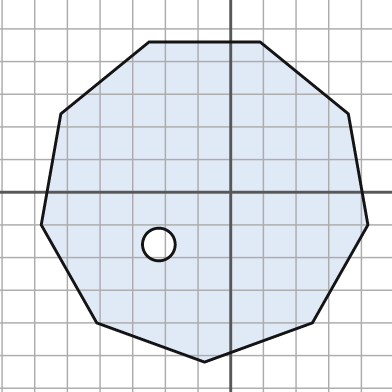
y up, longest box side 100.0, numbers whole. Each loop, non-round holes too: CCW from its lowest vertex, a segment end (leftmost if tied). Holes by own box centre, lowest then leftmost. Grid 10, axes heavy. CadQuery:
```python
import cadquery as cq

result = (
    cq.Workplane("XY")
    .moveTo(-8.0, -52.0)
    .lineTo(25.0, -40.0)
    .lineTo(42.0, -10.0)
    .lineTo(36.0, 24.0)
    .lineTo(9.0, 46.0)
    .lineTo(-25.0, 46.0)
    .lineTo(-52.0, 24.0)
    .lineTo(-58.0, -10.0)
    .lineTo(-41.0, -40.0)
    .close()
    .moveTo(-22.0, -16.0)
    .circle(5.0)
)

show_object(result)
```